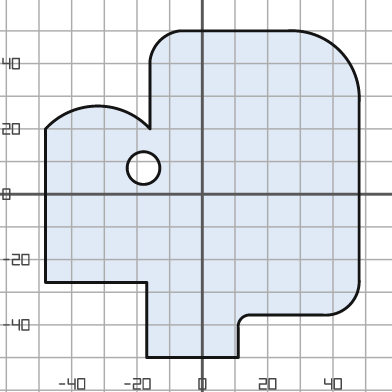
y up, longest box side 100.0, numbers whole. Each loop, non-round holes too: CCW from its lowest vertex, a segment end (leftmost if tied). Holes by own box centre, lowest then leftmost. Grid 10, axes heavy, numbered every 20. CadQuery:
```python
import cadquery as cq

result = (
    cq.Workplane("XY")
    .moveTo(-17.0, -50.0)
    .lineTo(11.0, -50.0)
    .lineTo(11.0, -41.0)
    .threePointArc((12.0, -38.0), (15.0, -37.0))
    .lineTo(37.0, -37.0)
    .threePointArc((45.0, -34.0), (48.0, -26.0))
    .lineTo(48.0, 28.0)
    .threePointArc((42.0, 44.0), (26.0, 50.0))
    .lineTo(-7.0, 50.0)
    .threePointArc((-13.0, 47.0), (-16.0, 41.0))
    .lineTo(-16.0, 20.0)
    .threePointArc((-32.0, 27.0), (-48.0, 20.0))
    .lineTo(-48.0, -27.0)
    .lineTo(-17.0, -27.0)
    .close()
    .moveTo(-18.0, 8.0)
    .circle(5.0)
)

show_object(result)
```